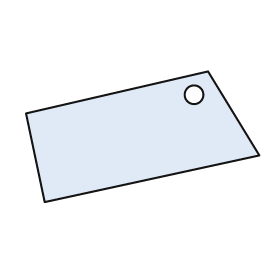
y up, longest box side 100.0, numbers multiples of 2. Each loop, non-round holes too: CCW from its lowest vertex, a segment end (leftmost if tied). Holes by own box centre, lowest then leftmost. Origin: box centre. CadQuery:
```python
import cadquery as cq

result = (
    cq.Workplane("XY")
    .moveTo(-42.0, -28.0)
    .lineTo(50.0, -8.0)
    .lineTo(28.0, 28.0)
    .lineTo(-50.0, 10.0)
    .close()
    .moveTo(22.0, 18.0)
    .circle(4.0)
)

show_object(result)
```